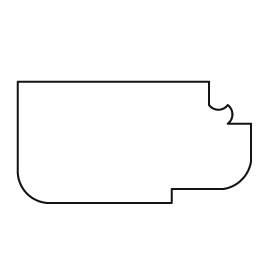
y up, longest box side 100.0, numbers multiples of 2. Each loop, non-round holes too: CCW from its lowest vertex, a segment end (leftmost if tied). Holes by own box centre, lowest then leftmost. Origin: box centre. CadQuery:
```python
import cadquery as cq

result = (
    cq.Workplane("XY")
    .moveTo(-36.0, -26.0)
    .lineTo(16.0, -26.0)
    .lineTo(16.0, -20.0)
    .lineTo(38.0, -20.0)
    .threePointArc((46.0, -16.0), (50.0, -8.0))
    .lineTo(50.0, 8.0)
    .lineTo(40.0, 8.0)
    .threePointArc((42.0, 12.0), (40.0, 16.0))
    .threePointArc((36.0, 14.0), (32.0, 16.0))
    .lineTo(32.0, 26.0)
    .lineTo(-50.0, 26.0)
    .lineTo(-50.0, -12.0)
    .threePointArc((-46.0, -22.0), (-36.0, -26.0))
    .close()
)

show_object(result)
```